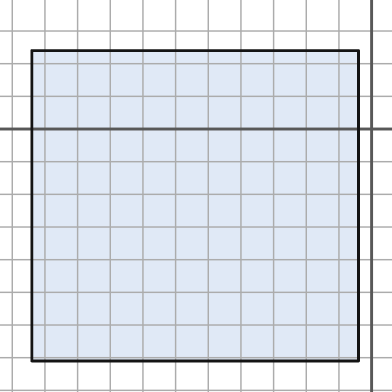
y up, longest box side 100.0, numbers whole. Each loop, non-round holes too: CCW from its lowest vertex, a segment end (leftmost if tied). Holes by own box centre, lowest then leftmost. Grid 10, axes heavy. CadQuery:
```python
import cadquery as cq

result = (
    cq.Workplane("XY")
    .moveTo(-104.0, -71.0)
    .lineTo(-4.0, -71.0)
    .lineTo(-4.0, 24.0)
    .lineTo(-104.0, 24.0)
    .close()
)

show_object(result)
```